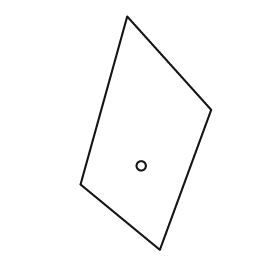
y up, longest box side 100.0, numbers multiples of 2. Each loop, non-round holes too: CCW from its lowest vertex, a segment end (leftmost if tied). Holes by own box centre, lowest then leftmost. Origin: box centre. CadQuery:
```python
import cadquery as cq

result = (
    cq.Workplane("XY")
    .moveTo(6.0, -50.0)
    .lineTo(28.0, 10.0)
    .lineTo(-8.0, 50.0)
    .lineTo(-28.0, -22.0)
    .close()
    .moveTo(-2.0, -14.0)
    .circle(2.0)
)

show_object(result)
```